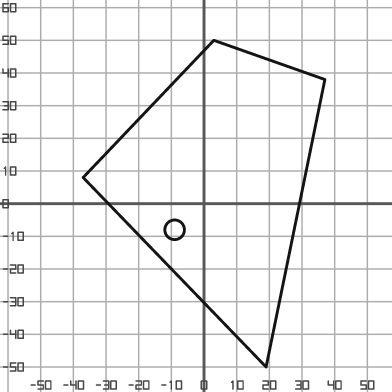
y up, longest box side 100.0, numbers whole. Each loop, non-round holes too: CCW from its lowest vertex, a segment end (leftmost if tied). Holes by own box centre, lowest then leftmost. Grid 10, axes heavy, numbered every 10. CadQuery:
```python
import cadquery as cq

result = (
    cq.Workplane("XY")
    .moveTo(19.0, -50.0)
    .lineTo(37.0, 38.0)
    .lineTo(3.0, 50.0)
    .lineTo(-37.0, 8.0)
    .close()
    .moveTo(-9.0, -8.0)
    .circle(3.0)
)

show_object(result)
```